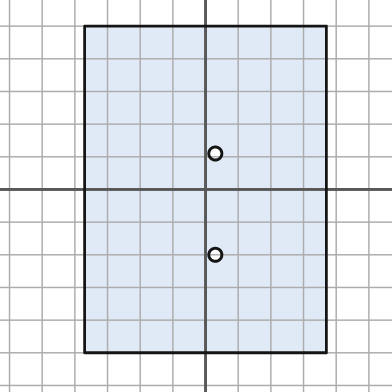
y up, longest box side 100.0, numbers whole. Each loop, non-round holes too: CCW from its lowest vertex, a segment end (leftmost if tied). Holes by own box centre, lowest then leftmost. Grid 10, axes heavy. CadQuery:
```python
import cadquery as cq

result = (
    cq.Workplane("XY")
    .moveTo(-37.0, -50.0)
    .lineTo(37.0, -50.0)
    .lineTo(37.0, 50.0)
    .lineTo(-37.0, 50.0)
    .close()
    .moveTo(3.0, -20.0)
    .circle(2.0)
    .moveTo(3.0, 11.0)
    .circle(2.0)
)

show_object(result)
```